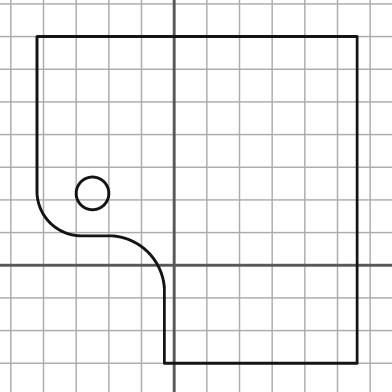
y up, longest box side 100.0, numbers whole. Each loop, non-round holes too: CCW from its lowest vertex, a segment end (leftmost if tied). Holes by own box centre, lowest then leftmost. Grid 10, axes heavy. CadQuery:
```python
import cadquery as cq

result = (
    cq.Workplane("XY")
    .moveTo(-3.0, -30.0)
    .lineTo(56.0, -30.0)
    .lineTo(56.0, 70.0)
    .lineTo(-42.0, 70.0)
    .lineTo(-42.0, 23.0)
    .threePointArc((-38.0, 13.0), (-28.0, 9.0))
    .lineTo(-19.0, 9.0)
    .threePointArc((-8.0, 4.0), (-3.0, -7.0))
    .close()
    .moveTo(-25.0, 22.0)
    .circle(5.0)
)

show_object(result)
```